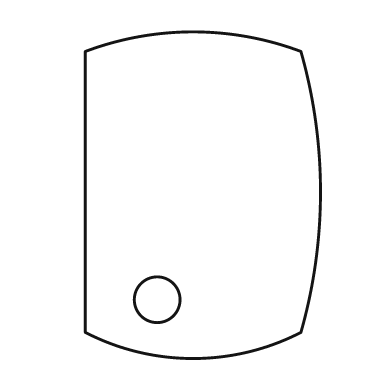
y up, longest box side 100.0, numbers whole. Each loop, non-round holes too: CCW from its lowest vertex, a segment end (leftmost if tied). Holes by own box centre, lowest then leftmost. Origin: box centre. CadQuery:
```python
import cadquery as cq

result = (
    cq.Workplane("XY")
    .moveTo(-36.0, -42.0)
    .threePointArc((-3.0, -50.0), (30.0, -42.0))
    .threePointArc((36.0, 1.0), (30.0, 44.0))
    .threePointArc((-3.0, 50.0), (-36.0, 44.0))
    .close()
    .moveTo(-14.0, -32.0)
    .circle(7.0)
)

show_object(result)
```